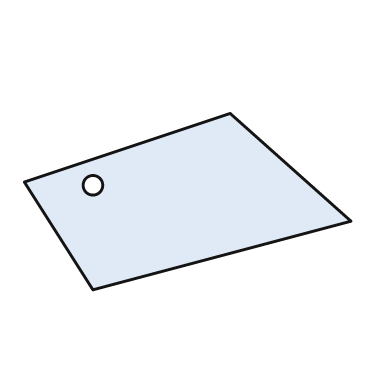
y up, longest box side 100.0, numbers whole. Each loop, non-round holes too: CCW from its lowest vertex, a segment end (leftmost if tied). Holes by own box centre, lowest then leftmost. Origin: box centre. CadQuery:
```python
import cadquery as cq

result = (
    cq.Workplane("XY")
    .moveTo(-29.0, -27.0)
    .lineTo(50.0, -6.0)
    .lineTo(13.0, 27.0)
    .lineTo(-50.0, 6.0)
    .close()
    .moveTo(-29.0, 5.0)
    .circle(3.0)
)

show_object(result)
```